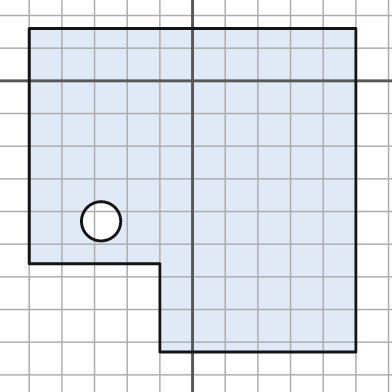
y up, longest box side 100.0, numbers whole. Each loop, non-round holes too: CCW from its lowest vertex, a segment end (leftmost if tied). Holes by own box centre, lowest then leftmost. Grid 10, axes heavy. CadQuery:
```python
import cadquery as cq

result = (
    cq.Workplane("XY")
    .moveTo(-10.0, -83.0)
    .lineTo(50.0, -83.0)
    .lineTo(50.0, 16.0)
    .lineTo(-50.0, 16.0)
    .lineTo(-50.0, -56.0)
    .lineTo(-10.0, -56.0)
    .close()
    .moveTo(-28.0, -43.0)
    .circle(6.0)
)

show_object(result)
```